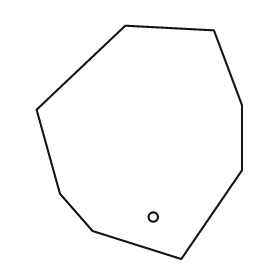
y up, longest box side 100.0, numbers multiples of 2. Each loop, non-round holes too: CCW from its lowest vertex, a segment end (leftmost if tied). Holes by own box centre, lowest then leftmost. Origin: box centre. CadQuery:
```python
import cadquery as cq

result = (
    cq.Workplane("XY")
    .moveTo(18.0, -50.0)
    .lineTo(44.0, -12.0)
    .lineTo(44.0, 16.0)
    .lineTo(32.0, 48.0)
    .lineTo(-6.0, 50.0)
    .lineTo(-44.0, 14.0)
    .lineTo(-34.0, -22.0)
    .lineTo(-20.0, -38.0)
    .close()
    .moveTo(6.0, -32.0)
    .circle(2.0)
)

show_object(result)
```